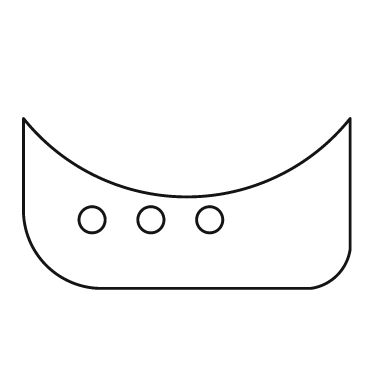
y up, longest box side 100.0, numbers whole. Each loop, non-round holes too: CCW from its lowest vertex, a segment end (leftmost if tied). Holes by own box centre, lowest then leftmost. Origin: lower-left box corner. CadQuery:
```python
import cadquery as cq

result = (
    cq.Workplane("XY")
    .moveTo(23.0, 0.0)
    .lineTo(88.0, 0.0)
    .threePointArc((96.0, 4.0), (100.0, 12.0))
    .lineTo(100.0, 52.0)
    .threePointArc((50.0, 28.0), (0.0, 52.0))
    .lineTo(0.0, 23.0)
    .threePointArc((7.0, 7.0), (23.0, 0.0))
    .close()
    .moveTo(21.0, 21.0)
    .circle(4.0)
    .moveTo(39.0, 21.0)
    .circle(4.0)
    .moveTo(57.0, 21.0)
    .circle(4.0)
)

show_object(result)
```